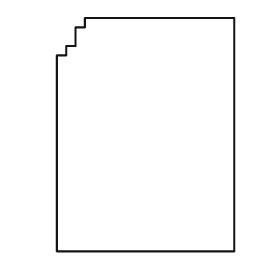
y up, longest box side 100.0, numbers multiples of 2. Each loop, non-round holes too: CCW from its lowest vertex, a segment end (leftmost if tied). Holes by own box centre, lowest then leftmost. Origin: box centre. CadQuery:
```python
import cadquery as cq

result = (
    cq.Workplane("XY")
    .moveTo(-38.0, -50.0)
    .lineTo(38.0, -50.0)
    .lineTo(38.0, 50.0)
    .lineTo(-26.0, 50.0)
    .lineTo(-26.0, 46.0)
    .lineTo(-30.0, 46.0)
    .lineTo(-30.0, 38.0)
    .lineTo(-34.0, 38.0)
    .lineTo(-34.0, 34.0)
    .lineTo(-38.0, 34.0)
    .close()
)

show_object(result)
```